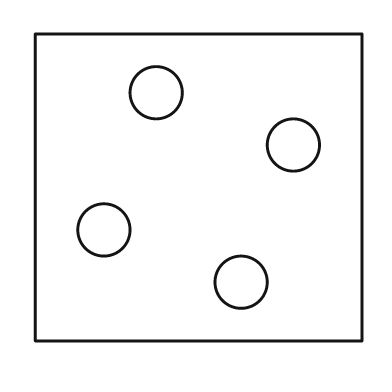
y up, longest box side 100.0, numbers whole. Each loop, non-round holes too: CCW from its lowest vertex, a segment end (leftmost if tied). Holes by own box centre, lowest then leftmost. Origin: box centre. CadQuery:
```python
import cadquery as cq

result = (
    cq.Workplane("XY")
    .moveTo(-50.0, -47.0)
    .lineTo(50.0, -47.0)
    .lineTo(50.0, 47.0)
    .lineTo(-50.0, 47.0)
    .close()
    .moveTo(13.0, -29.0)
    .circle(8.0)
    .moveTo(-29.0, -13.0)
    .circle(8.0)
    .moveTo(29.0, 13.0)
    .circle(8.0)
    .moveTo(-13.0, 29.0)
    .circle(8.0)
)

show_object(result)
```